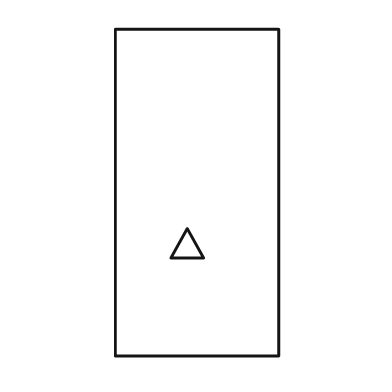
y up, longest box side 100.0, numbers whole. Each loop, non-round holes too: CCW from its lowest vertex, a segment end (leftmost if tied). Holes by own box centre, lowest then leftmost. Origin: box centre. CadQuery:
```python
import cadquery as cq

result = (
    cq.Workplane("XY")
    .moveTo(-25.0, -50.0)
    .lineTo(25.0, -50.0)
    .lineTo(25.0, 50.0)
    .lineTo(-25.0, 50.0)
    .close()
    .moveTo(-8.0, -20.0)
    .lineTo(2.0, -20.0)
    .lineTo(-3.0, -11.0)
    .close()
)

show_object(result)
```